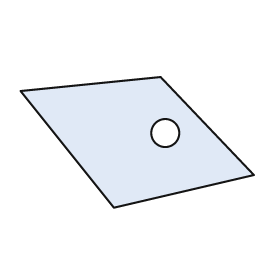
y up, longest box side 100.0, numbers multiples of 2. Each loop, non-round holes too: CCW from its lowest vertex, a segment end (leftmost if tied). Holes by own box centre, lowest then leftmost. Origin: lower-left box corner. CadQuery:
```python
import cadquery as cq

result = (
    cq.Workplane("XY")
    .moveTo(40.0, 0.0)
    .lineTo(100.0, 14.0)
    .lineTo(60.0, 56.0)
    .lineTo(0.0, 50.0)
    .close()
    .moveTo(62.0, 32.0)
    .circle(6.0)
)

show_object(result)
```